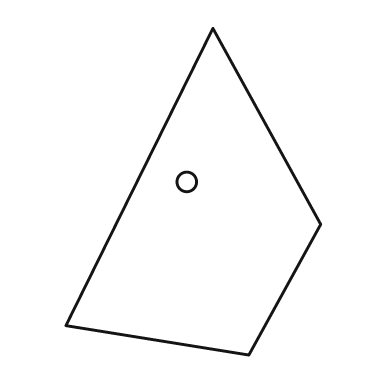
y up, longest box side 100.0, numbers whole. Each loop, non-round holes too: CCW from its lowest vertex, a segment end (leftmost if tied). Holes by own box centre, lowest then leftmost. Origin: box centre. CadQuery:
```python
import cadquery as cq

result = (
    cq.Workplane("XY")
    .moveTo(17.0, -50.0)
    .lineTo(39.0, -10.0)
    .lineTo(6.0, 50.0)
    .lineTo(-39.0, -41.0)
    .close()
    .moveTo(-2.0, 3.0)
    .circle(3.0)
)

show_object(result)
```